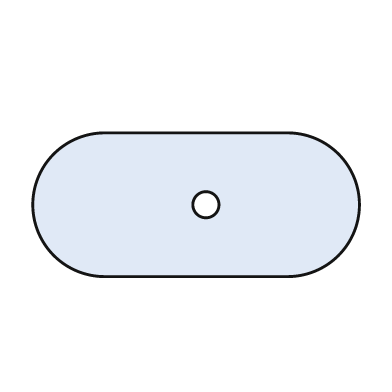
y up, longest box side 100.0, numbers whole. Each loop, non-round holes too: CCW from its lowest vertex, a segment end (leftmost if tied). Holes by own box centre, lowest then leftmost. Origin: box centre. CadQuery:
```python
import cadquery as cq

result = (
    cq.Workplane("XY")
    .moveTo(-28.0, -22.0)
    .lineTo(28.0, -22.0)
    .threePointArc((50.0, 0.0), (28.0, 22.0))
    .lineTo(-28.0, 22.0)
    .threePointArc((-50.0, 0.0), (-28.0, -22.0))
    .close()
    .moveTo(3.0, 0.0)
    .circle(4.0)
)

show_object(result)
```